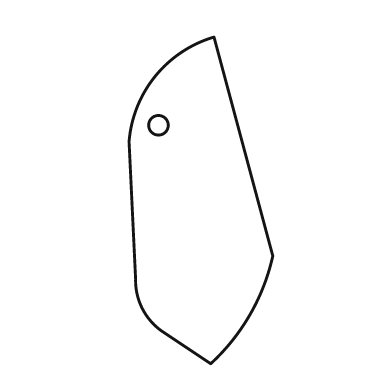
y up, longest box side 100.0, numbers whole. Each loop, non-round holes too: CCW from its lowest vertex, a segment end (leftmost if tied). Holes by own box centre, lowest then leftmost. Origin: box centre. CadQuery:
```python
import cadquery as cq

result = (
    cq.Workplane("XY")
    .moveTo(3.0, -50.0)
    .threePointArc((15.0, -35.0), (22.0, -17.0))
    .lineTo(4.0, 50.0)
    .threePointArc((-14.0, 38.0), (-22.0, 18.0))
    .lineTo(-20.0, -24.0)
    .threePointArc((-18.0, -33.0), (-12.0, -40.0))
    .close()
    .moveTo(-13.0, 23.0)
    .circle(3.0)
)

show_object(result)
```